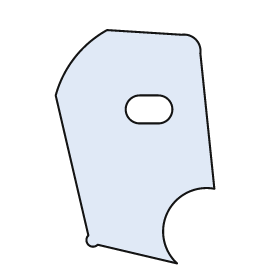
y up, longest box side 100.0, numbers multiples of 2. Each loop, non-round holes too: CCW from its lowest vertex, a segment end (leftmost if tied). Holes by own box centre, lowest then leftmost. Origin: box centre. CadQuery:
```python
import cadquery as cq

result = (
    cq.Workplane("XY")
    .moveTo(18.0, -50.0)
    .threePointArc((14.0, -28.0), (34.0, -18.0))
    .lineTo(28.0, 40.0)
    .threePointArc((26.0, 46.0), (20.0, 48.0))
    .lineTo(-12.0, 50.0)
    .threePointArc((-26.0, 38.0), (-34.0, 22.0))
    .lineTo(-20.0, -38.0)
    .threePointArc((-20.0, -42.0), (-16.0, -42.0))
    .close()
    .moveTo(2.0, 10.0)
    .lineTo(10.0, 10.0)
    .threePointArc((16.0, 16.0), (10.0, 22.0))
    .lineTo(2.0, 22.0)
    .threePointArc((-4.0, 16.0), (2.0, 10.0))
    .close()
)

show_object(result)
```